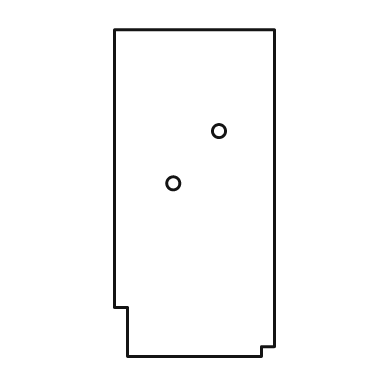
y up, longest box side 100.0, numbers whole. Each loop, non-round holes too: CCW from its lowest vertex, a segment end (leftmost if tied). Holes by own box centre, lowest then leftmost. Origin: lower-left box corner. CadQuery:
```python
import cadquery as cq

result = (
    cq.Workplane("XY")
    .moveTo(4.0, 0.0)
    .lineTo(45.0, 0.0)
    .lineTo(45.0, 3.0)
    .lineTo(49.0, 3.0)
    .lineTo(49.0, 100.0)
    .lineTo(0.0, 100.0)
    .lineTo(0.0, 15.0)
    .lineTo(4.0, 15.0)
    .close()
    .moveTo(18.0, 53.0)
    .circle(2.0)
    .moveTo(32.0, 69.0)
    .circle(2.0)
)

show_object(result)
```